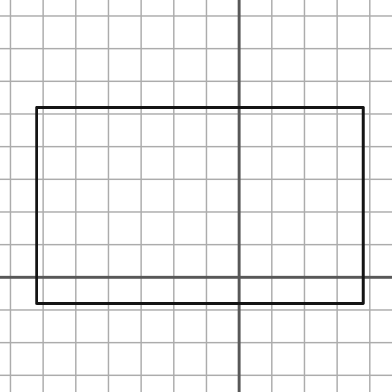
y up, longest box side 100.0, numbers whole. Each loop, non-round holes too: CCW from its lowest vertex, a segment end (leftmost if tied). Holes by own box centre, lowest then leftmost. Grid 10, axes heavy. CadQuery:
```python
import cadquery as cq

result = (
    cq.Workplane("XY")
    .moveTo(-62.0, -8.0)
    .lineTo(38.0, -8.0)
    .lineTo(38.0, 52.0)
    .lineTo(-62.0, 52.0)
    .close()
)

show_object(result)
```